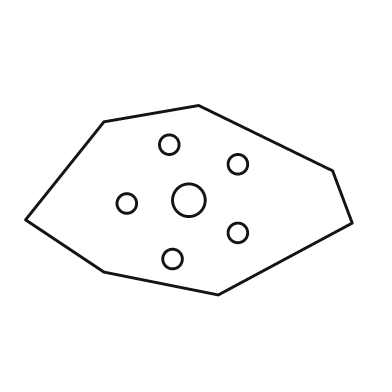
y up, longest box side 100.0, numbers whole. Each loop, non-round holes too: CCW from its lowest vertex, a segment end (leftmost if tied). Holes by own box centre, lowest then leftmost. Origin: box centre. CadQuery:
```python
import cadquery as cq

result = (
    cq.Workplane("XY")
    .moveTo(9.0, -29.0)
    .lineTo(50.0, -7.0)
    .lineTo(44.0, 9.0)
    .lineTo(3.0, 29.0)
    .lineTo(-26.0, 24.0)
    .lineTo(-50.0, -6.0)
    .lineTo(-26.0, -22.0)
    .close()
    .moveTo(-5.0, -18.0)
    .circle(3.0)
    .moveTo(15.0, -10.0)
    .circle(3.0)
    .moveTo(-19.0, -1.0)
    .circle(3.0)
    .moveTo(0.0, 0.0)
    .circle(5.0)
    .moveTo(15.0, 11.0)
    .circle(3.0)
    .moveTo(-6.0, 17.0)
    .circle(3.0)
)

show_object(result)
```